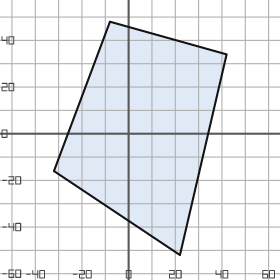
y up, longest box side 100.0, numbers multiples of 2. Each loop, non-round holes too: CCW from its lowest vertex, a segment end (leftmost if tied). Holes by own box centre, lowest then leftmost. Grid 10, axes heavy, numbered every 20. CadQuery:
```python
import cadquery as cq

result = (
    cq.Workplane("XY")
    .moveTo(22.0, -52.0)
    .lineTo(42.0, 34.0)
    .lineTo(-8.0, 48.0)
    .lineTo(-32.0, -16.0)
    .close()
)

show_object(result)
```